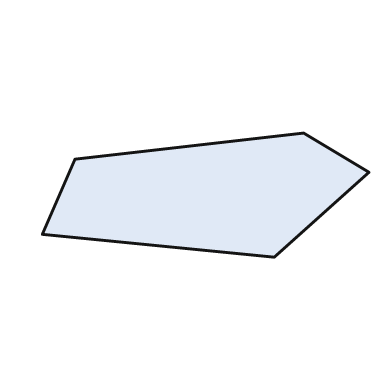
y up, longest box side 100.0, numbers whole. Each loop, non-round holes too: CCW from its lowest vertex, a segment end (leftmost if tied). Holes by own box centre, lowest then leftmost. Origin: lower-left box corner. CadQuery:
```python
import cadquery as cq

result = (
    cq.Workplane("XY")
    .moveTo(71.0, 0.0)
    .lineTo(100.0, 26.0)
    .lineTo(80.0, 38.0)
    .lineTo(10.0, 30.0)
    .lineTo(0.0, 7.0)
    .close()
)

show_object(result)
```